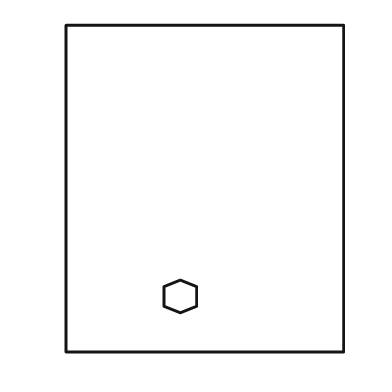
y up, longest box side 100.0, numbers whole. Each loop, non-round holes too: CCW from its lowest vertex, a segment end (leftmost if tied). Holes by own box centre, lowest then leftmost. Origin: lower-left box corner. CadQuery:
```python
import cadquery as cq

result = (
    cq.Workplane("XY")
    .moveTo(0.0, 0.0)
    .lineTo(85.0, 0.0)
    .lineTo(85.0, 100.0)
    .lineTo(0.0, 100.0)
    .close()
    .moveTo(35.0, 12.0)
    .lineTo(40.0, 14.0)
    .lineTo(40.0, 20.0)
    .lineTo(35.0, 22.0)
    .lineTo(30.0, 20.0)
    .lineTo(30.0, 14.0)
    .close()
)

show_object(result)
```